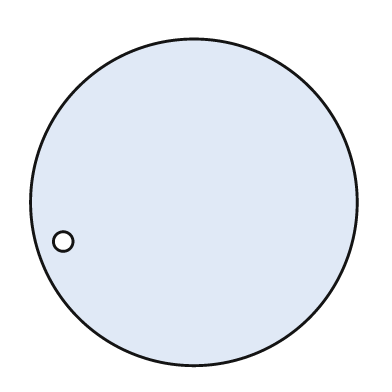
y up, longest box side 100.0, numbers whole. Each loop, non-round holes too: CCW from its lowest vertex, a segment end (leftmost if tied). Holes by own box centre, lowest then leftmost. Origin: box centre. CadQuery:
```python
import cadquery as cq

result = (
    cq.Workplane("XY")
    .moveTo(0.0, 0.0)
    .circle(50.0)
    .moveTo(-40.0, -12.0)
    .circle(3.0)
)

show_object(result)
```